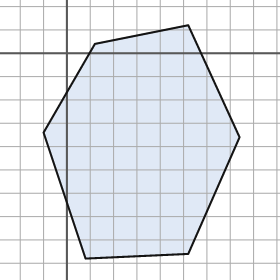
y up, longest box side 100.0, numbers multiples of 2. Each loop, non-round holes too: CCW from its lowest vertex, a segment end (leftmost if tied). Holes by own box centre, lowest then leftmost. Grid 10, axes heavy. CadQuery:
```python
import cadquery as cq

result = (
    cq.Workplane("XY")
    .moveTo(8.0, -88.0)
    .lineTo(52.0, -86.0)
    .lineTo(74.0, -36.0)
    .lineTo(52.0, 12.0)
    .lineTo(12.0, 4.0)
    .lineTo(-10.0, -34.0)
    .close()
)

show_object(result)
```